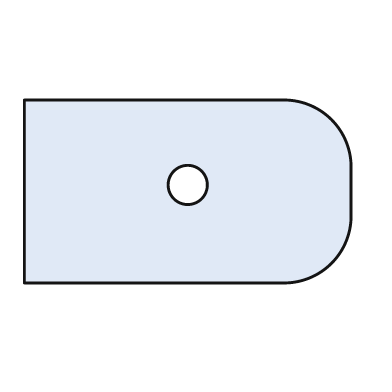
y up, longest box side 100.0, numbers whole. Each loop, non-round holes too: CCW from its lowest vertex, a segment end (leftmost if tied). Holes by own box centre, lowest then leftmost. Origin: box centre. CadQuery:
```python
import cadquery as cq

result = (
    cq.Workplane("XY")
    .moveTo(-50.0, -28.0)
    .lineTo(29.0, -28.0)
    .threePointArc((44.0, -22.0), (50.0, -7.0))
    .lineTo(50.0, 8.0)
    .threePointArc((44.0, 22.0), (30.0, 28.0))
    .lineTo(-50.0, 28.0)
    .close()
    .moveTo(0.0, 2.0)
    .circle(6.0)
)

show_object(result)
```